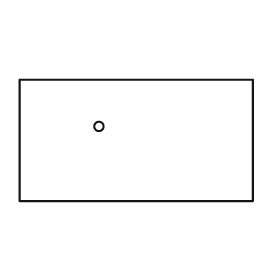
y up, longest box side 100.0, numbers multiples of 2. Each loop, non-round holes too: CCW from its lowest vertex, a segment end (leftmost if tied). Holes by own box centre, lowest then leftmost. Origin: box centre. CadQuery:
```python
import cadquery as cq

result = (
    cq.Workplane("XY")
    .moveTo(-50.0, -26.0)
    .lineTo(50.0, -26.0)
    .lineTo(50.0, 26.0)
    .lineTo(-50.0, 26.0)
    .close()
    .moveTo(-16.0, 6.0)
    .circle(2.0)
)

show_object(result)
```